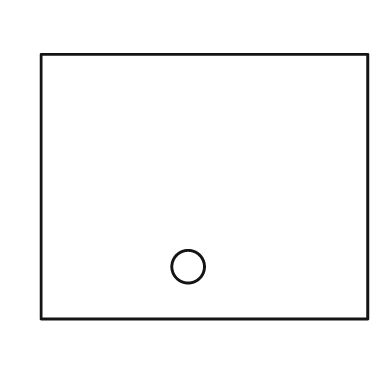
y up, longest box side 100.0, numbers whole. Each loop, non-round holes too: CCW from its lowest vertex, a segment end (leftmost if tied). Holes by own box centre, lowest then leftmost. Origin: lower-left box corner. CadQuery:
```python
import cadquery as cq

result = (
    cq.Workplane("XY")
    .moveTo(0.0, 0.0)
    .lineTo(100.0, 0.0)
    .lineTo(100.0, 81.0)
    .lineTo(0.0, 81.0)
    .close()
    .moveTo(45.0, 16.0)
    .circle(5.0)
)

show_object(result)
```